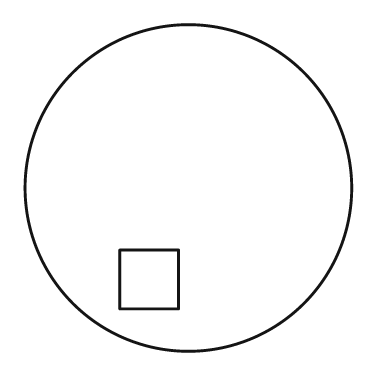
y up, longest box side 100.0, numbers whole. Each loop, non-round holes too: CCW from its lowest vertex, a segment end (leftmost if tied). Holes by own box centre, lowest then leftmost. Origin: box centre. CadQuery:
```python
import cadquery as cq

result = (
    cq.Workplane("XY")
    .moveTo(0.0, 0.0)
    .circle(50.0)
    .moveTo(-21.0, -37.0)
    .lineTo(-3.0, -37.0)
    .lineTo(-3.0, -19.0)
    .lineTo(-21.0, -19.0)
    .close()
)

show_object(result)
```